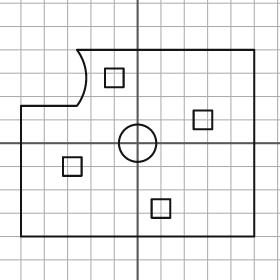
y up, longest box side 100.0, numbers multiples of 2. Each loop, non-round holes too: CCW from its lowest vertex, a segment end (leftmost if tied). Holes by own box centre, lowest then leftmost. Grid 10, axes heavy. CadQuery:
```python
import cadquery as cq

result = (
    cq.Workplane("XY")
    .moveTo(-50.0, -40.0)
    .lineTo(50.0, -40.0)
    .lineTo(50.0, 40.0)
    .lineTo(-26.0, 40.0)
    .threePointArc((-22.0, 28.0), (-26.0, 16.0))
    .lineTo(-50.0, 16.0)
    .close()
    .moveTo(6.0, -32.0)
    .lineTo(14.0, -32.0)
    .lineTo(14.0, -24.0)
    .lineTo(6.0, -24.0)
    .close()
    .moveTo(-32.0, -14.0)
    .lineTo(-24.0, -14.0)
    .lineTo(-24.0, -6.0)
    .lineTo(-32.0, -6.0)
    .close()
    .moveTo(0.0, 0.0)
    .circle(8.0)
    .moveTo(24.0, 6.0)
    .lineTo(32.0, 6.0)
    .lineTo(32.0, 14.0)
    .lineTo(24.0, 14.0)
    .close()
    .moveTo(-14.0, 24.0)
    .lineTo(-6.0, 24.0)
    .lineTo(-6.0, 32.0)
    .lineTo(-14.0, 32.0)
    .close()
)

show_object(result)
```